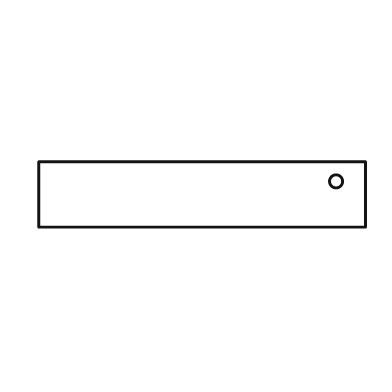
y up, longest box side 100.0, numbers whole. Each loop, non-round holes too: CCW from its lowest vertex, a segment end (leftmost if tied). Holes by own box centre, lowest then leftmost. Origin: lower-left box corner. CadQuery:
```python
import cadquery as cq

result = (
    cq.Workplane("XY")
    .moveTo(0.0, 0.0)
    .lineTo(100.0, 0.0)
    .lineTo(100.0, 20.0)
    .lineTo(0.0, 20.0)
    .close()
    .moveTo(91.0, 14.0)
    .circle(2.0)
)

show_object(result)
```